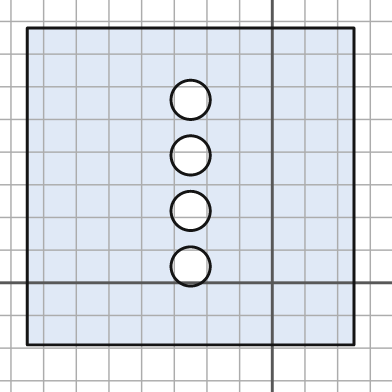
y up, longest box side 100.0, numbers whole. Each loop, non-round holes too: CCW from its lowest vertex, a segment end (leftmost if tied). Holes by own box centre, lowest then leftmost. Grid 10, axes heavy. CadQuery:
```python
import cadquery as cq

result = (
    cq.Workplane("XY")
    .moveTo(-75.0, -19.0)
    .lineTo(25.0, -19.0)
    .lineTo(25.0, 78.0)
    .lineTo(-75.0, 78.0)
    .close()
    .moveTo(-25.0, 5.0)
    .circle(6.0)
    .moveTo(-25.0, 22.0)
    .circle(6.0)
    .moveTo(-25.0, 39.0)
    .circle(6.0)
    .moveTo(-25.0, 56.0)
    .circle(6.0)
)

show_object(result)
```